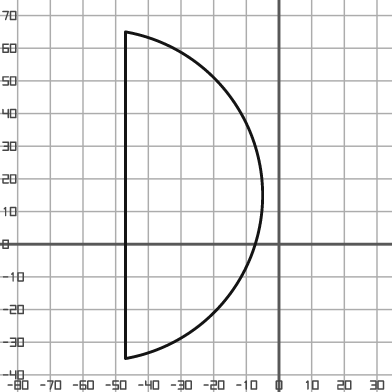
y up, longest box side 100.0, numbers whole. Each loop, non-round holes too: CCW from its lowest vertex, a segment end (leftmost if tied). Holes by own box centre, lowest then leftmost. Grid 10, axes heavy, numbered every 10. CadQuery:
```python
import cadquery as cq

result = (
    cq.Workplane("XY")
    .moveTo(-47.0, -35.0)
    .threePointArc((-5.0, 15.0), (-47.0, 65.0))
    .close()
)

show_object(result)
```